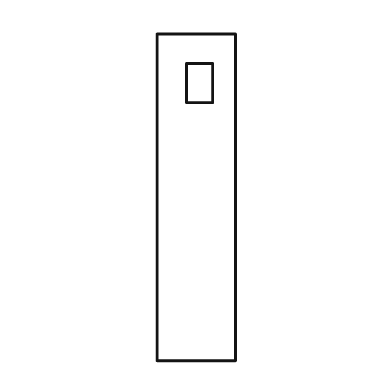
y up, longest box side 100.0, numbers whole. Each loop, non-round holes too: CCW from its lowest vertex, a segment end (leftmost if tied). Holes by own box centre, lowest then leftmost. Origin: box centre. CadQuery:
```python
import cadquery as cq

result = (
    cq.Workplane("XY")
    .moveTo(-12.0, -50.0)
    .lineTo(12.0, -50.0)
    .lineTo(12.0, 50.0)
    .lineTo(-12.0, 50.0)
    .close()
    .moveTo(-3.0, 29.0)
    .lineTo(5.0, 29.0)
    .lineTo(5.0, 41.0)
    .lineTo(-3.0, 41.0)
    .close()
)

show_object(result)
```